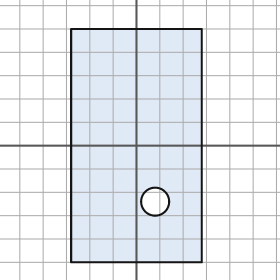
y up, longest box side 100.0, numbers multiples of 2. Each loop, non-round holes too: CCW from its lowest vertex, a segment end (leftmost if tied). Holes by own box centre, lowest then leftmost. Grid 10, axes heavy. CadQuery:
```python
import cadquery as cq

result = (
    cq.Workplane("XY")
    .moveTo(-28.0, -50.0)
    .lineTo(28.0, -50.0)
    .lineTo(28.0, 50.0)
    .lineTo(-28.0, 50.0)
    .close()
    .moveTo(8.0, -24.0)
    .circle(6.0)
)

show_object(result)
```